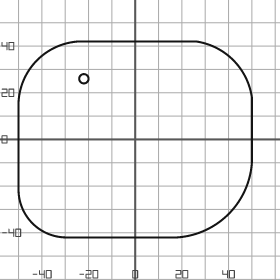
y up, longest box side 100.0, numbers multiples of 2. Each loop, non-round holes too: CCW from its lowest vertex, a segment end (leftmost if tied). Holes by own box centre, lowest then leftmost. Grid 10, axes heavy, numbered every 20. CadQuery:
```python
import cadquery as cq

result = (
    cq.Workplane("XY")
    .moveTo(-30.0, -42.0)
    .lineTo(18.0, -42.0)
    .threePointArc((40.0, -32.0), (50.0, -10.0))
    .lineTo(50.0, 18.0)
    .threePointArc((42.0, 34.0), (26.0, 42.0))
    .lineTo(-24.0, 42.0)
    .threePointArc((-42.0, 34.0), (-50.0, 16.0))
    .lineTo(-50.0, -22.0)
    .threePointArc((-44.0, -36.0), (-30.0, -42.0))
    .close()
    .moveTo(-22.0, 26.0)
    .circle(2.0)
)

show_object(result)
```